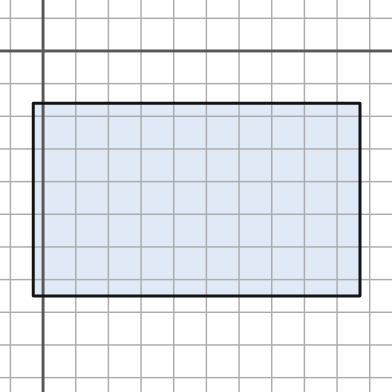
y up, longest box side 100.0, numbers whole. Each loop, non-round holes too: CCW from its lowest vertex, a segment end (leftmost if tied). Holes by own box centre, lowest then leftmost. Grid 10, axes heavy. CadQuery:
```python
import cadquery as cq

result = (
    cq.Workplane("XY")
    .moveTo(-3.0, -75.0)
    .lineTo(97.0, -75.0)
    .lineTo(97.0, -16.0)
    .lineTo(-3.0, -16.0)
    .close()
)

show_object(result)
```